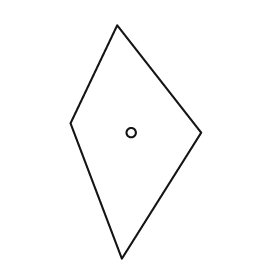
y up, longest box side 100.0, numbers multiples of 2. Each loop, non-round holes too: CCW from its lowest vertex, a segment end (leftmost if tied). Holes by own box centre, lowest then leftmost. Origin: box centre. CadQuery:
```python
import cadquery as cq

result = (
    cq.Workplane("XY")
    .moveTo(-6.0, -50.0)
    .lineTo(28.0, 4.0)
    .lineTo(-8.0, 50.0)
    .lineTo(-28.0, 8.0)
    .close()
    .moveTo(-2.0, 4.0)
    .circle(2.0)
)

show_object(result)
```